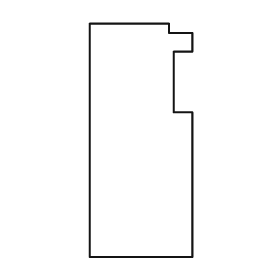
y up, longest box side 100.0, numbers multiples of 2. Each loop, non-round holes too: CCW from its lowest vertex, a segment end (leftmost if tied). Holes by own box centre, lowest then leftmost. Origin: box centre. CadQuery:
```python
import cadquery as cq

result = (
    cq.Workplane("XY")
    .moveTo(-22.0, -50.0)
    .lineTo(22.0, -50.0)
    .lineTo(22.0, 12.0)
    .lineTo(14.0, 12.0)
    .lineTo(14.0, 38.0)
    .lineTo(22.0, 38.0)
    .lineTo(22.0, 46.0)
    .lineTo(12.0, 46.0)
    .lineTo(12.0, 50.0)
    .lineTo(-22.0, 50.0)
    .close()
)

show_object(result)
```